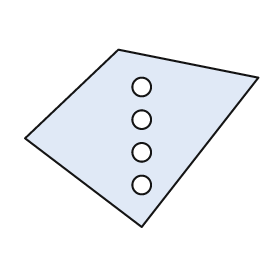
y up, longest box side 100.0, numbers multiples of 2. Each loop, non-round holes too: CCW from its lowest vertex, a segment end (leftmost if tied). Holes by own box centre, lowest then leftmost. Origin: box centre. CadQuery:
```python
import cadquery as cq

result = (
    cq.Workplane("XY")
    .moveTo(0.0, -38.0)
    .lineTo(50.0, 26.0)
    .lineTo(-10.0, 38.0)
    .lineTo(-50.0, 0.0)
    .close()
    .moveTo(0.0, -20.0)
    .circle(4.0)
    .moveTo(0.0, -6.0)
    .circle(4.0)
    .moveTo(0.0, 8.0)
    .circle(4.0)
    .moveTo(0.0, 22.0)
    .circle(4.0)
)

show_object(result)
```